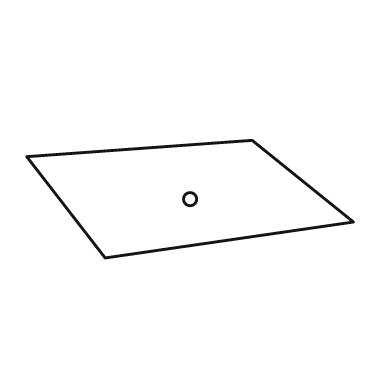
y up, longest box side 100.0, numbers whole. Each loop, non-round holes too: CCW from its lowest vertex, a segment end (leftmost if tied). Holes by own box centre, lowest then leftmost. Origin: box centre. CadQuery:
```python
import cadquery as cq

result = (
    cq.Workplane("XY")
    .moveTo(-26.0, -18.0)
    .lineTo(50.0, -7.0)
    .lineTo(19.0, 18.0)
    .lineTo(-50.0, 13.0)
    .close()
    .moveTo(0.0, 0.0)
    .circle(2.0)
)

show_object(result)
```